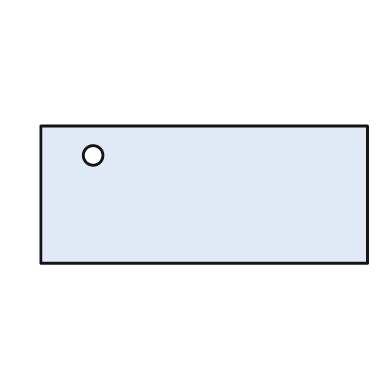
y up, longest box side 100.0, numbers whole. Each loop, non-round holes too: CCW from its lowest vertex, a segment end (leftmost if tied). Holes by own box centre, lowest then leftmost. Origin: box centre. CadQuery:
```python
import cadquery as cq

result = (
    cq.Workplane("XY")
    .moveTo(-50.0, -21.0)
    .lineTo(50.0, -21.0)
    .lineTo(50.0, 21.0)
    .lineTo(-50.0, 21.0)
    .close()
    .moveTo(-34.0, 12.0)
    .circle(3.0)
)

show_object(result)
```